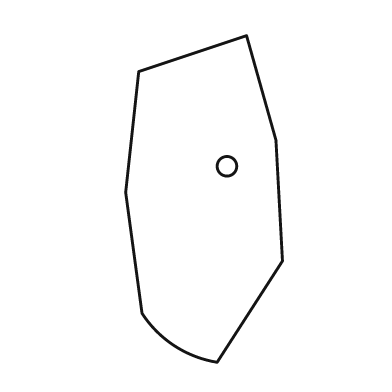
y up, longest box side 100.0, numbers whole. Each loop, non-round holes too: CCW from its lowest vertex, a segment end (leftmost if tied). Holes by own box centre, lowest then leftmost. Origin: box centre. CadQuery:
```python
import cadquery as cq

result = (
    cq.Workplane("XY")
    .moveTo(4.0, -50.0)
    .lineTo(24.0, -19.0)
    .lineTo(22.0, 18.0)
    .lineTo(13.0, 50.0)
    .lineTo(-20.0, 39.0)
    .lineTo(-24.0, 2.0)
    .lineTo(-19.0, -35.0)
    .threePointArc((-9.0, -45.0), (4.0, -50.0))
    .close()
    .moveTo(7.0, 10.0)
    .circle(3.0)
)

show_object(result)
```